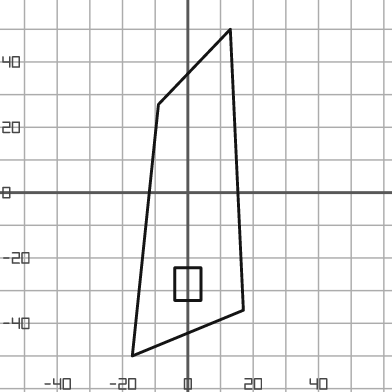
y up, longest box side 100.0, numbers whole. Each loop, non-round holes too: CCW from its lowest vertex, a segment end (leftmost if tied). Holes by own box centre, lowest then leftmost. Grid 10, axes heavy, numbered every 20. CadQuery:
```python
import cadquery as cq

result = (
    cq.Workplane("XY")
    .moveTo(-17.0, -50.0)
    .lineTo(17.0, -36.0)
    .lineTo(13.0, 50.0)
    .lineTo(-9.0, 27.0)
    .close()
    .moveTo(-4.0, -33.0)
    .lineTo(4.0, -33.0)
    .lineTo(4.0, -23.0)
    .lineTo(-4.0, -23.0)
    .close()
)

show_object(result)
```